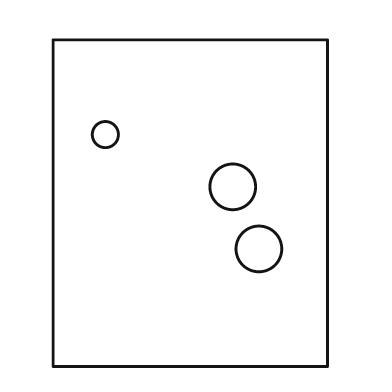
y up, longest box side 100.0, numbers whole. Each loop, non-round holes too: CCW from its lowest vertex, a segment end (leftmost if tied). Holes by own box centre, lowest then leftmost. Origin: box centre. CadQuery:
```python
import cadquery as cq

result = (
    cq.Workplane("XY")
    .moveTo(-42.0, -50.0)
    .lineTo(42.0, -50.0)
    .lineTo(42.0, 50.0)
    .lineTo(-42.0, 50.0)
    .close()
    .moveTo(21.0, -14.0)
    .circle(7.0)
    .moveTo(13.0, 5.0)
    .circle(7.0)
    .moveTo(-26.0, 21.0)
    .circle(4.0)
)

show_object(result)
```